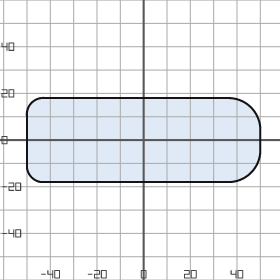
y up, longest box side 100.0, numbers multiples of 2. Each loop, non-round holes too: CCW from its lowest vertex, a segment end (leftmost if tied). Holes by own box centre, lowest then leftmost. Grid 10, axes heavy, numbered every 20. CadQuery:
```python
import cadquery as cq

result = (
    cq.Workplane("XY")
    .moveTo(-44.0, -18.0)
    .lineTo(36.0, -18.0)
    .threePointArc((46.0, -14.0), (50.0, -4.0))
    .lineTo(50.0, 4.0)
    .threePointArc((46.0, 14.0), (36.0, 18.0))
    .lineTo(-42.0, 18.0)
    .threePointArc((-48.0, 16.0), (-50.0, 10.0))
    .lineTo(-50.0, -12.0)
    .threePointArc((-48.0, -16.0), (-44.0, -18.0))
    .close()
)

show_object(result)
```